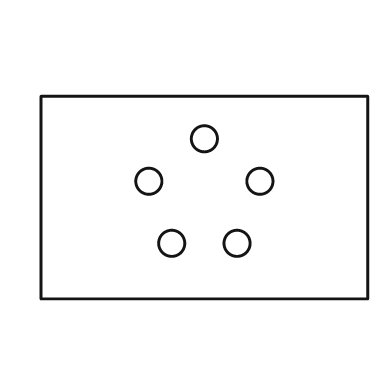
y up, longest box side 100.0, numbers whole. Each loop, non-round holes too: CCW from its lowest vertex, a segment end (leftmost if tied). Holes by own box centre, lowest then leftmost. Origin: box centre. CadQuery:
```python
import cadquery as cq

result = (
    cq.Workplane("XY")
    .moveTo(-50.0, -31.0)
    .lineTo(50.0, -31.0)
    .lineTo(50.0, 31.0)
    .lineTo(-50.0, 31.0)
    .close()
    .moveTo(-10.0, -14.0)
    .circle(4.0)
    .moveTo(10.0, -14.0)
    .circle(4.0)
    .moveTo(-17.0, 5.0)
    .circle(4.0)
    .moveTo(17.0, 5.0)
    .circle(4.0)
    .moveTo(0.0, 18.0)
    .circle(4.0)
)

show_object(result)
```